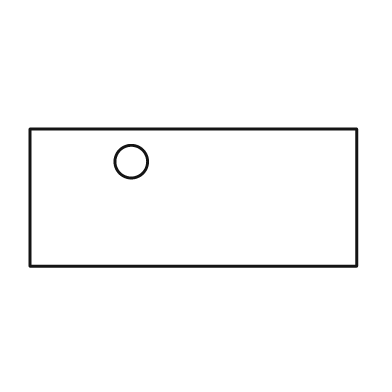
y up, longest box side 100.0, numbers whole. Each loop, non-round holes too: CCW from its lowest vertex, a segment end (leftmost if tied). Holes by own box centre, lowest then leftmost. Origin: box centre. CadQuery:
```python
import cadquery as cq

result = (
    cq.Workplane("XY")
    .moveTo(-50.0, -21.0)
    .lineTo(50.0, -21.0)
    .lineTo(50.0, 21.0)
    .lineTo(-50.0, 21.0)
    .close()
    .moveTo(-19.0, 11.0)
    .circle(5.0)
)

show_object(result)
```